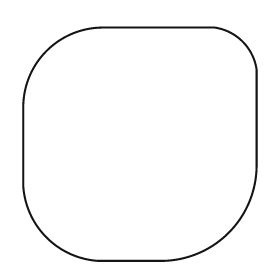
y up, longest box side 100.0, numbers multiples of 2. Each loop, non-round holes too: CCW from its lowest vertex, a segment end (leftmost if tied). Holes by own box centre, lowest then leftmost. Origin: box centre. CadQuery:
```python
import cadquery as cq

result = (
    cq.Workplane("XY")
    .moveTo(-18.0, -50.0)
    .lineTo(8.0, -50.0)
    .threePointArc((38.0, -38.0), (50.0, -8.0))
    .lineTo(50.0, 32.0)
    .threePointArc((44.0, 44.0), (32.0, 50.0))
    .lineTo(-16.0, 50.0)
    .threePointArc((-40.0, 40.0), (-50.0, 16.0))
    .lineTo(-50.0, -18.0)
    .threePointArc((-40.0, -40.0), (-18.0, -50.0))
    .close()
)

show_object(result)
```